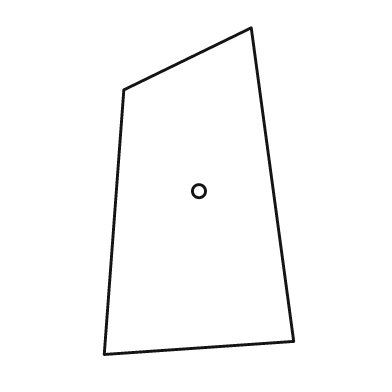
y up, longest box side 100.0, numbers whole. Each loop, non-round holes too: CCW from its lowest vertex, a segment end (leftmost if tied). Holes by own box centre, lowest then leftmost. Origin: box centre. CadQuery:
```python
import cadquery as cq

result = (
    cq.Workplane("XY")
    .moveTo(-29.0, -50.0)
    .lineTo(29.0, -46.0)
    .lineTo(16.0, 50.0)
    .lineTo(-23.0, 31.0)
    .close()
    .moveTo(0.0, 0.0)
    .circle(2.0)
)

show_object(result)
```